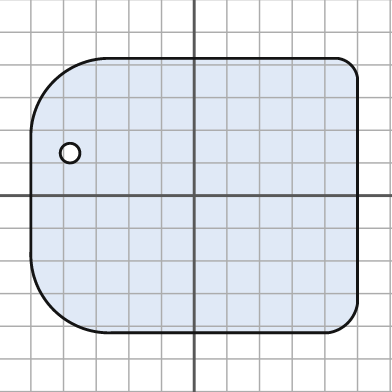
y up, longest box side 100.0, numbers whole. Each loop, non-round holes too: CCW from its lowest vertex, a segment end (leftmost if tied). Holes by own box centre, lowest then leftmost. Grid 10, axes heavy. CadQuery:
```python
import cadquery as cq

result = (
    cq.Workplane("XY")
    .moveTo(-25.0, -42.0)
    .lineTo(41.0, -42.0)
    .threePointArc((47.0, -39.0), (50.0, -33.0))
    .lineTo(50.0, 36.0)
    .threePointArc((48.0, 40.0), (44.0, 42.0))
    .lineTo(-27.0, 42.0)
    .threePointArc((-43.0, 35.0), (-50.0, 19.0))
    .lineTo(-50.0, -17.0)
    .threePointArc((-43.0, -35.0), (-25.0, -42.0))
    .close()
    .moveTo(-38.0, 13.0)
    .circle(3.0)
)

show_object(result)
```